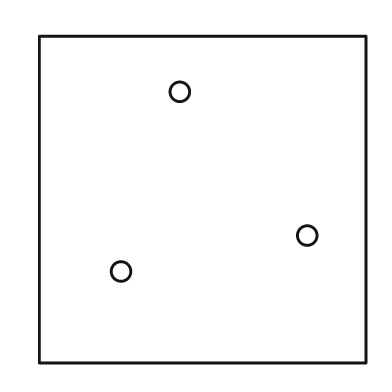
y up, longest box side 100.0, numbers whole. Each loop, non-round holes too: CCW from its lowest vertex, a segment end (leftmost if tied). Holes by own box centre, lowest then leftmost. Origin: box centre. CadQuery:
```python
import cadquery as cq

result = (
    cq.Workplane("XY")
    .moveTo(-50.0, -50.0)
    .lineTo(50.0, -50.0)
    .lineTo(50.0, 50.0)
    .lineTo(-50.0, 50.0)
    .close()
    .moveTo(-25.0, -22.0)
    .circle(3.0)
    .moveTo(32.0, -11.0)
    .circle(3.0)
    .moveTo(-7.0, 33.0)
    .circle(3.0)
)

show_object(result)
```